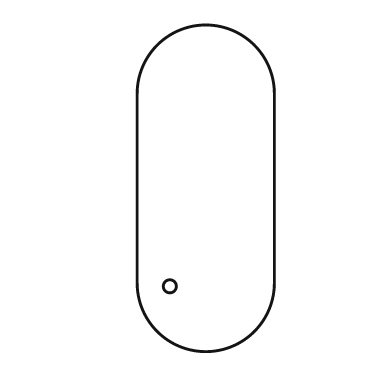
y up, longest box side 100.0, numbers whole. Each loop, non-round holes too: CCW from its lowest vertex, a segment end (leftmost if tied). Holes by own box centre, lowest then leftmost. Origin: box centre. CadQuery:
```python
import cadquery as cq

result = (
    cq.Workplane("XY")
    .moveTo(-21.0, -29.0)
    .threePointArc((0.0, -50.0), (21.0, -29.0))
    .lineTo(21.0, 29.0)
    .threePointArc((0.0, 50.0), (-21.0, 29.0))
    .close()
    .moveTo(-11.0, -30.0)
    .circle(2.0)
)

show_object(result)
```